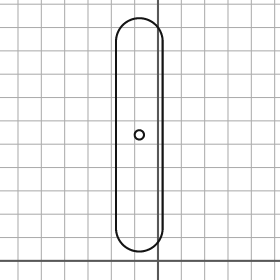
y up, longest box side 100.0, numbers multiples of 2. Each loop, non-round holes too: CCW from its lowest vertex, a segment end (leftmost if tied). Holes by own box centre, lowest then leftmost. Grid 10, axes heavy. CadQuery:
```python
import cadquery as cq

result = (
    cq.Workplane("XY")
    .moveTo(-18.0, 14.0)
    .threePointArc((-8.0, 4.0), (2.0, 14.0))
    .lineTo(2.0, 94.0)
    .threePointArc((-8.0, 104.0), (-18.0, 94.0))
    .close()
    .moveTo(-8.0, 54.0)
    .circle(2.0)
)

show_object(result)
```